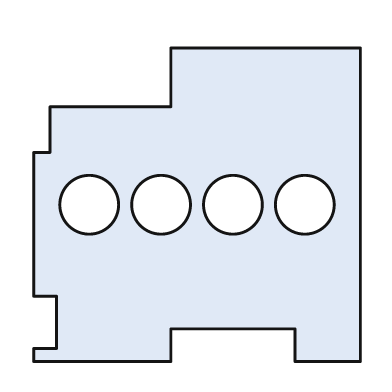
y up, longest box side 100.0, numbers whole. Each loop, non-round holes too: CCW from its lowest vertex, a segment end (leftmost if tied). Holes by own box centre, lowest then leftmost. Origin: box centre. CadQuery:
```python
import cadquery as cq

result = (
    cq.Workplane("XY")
    .moveTo(-50.0, -48.0)
    .lineTo(-8.0, -48.0)
    .lineTo(-8.0, -38.0)
    .lineTo(30.0, -38.0)
    .lineTo(30.0, -48.0)
    .lineTo(50.0, -48.0)
    .lineTo(50.0, 48.0)
    .lineTo(-8.0, 48.0)
    .lineTo(-8.0, 30.0)
    .lineTo(-45.0, 30.0)
    .lineTo(-45.0, 16.0)
    .lineTo(-50.0, 16.0)
    .lineTo(-50.0, -28.0)
    .lineTo(-43.0, -28.0)
    .lineTo(-43.0, -44.0)
    .lineTo(-50.0, -44.0)
    .close()
    .moveTo(-33.0, 0.0)
    .circle(9.0)
    .moveTo(-11.0, 0.0)
    .circle(9.0)
    .moveTo(11.0, 0.0)
    .circle(9.0)
    .moveTo(33.0, 0.0)
    .circle(9.0)
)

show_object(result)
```